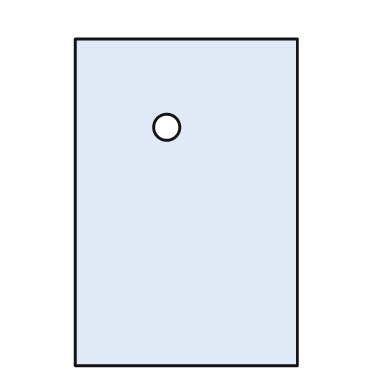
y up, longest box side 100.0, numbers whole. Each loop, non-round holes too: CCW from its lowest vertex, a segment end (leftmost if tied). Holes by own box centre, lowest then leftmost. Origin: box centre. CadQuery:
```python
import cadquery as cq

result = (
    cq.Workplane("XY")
    .moveTo(-34.0, -50.0)
    .lineTo(34.0, -50.0)
    .lineTo(34.0, 50.0)
    .lineTo(-34.0, 50.0)
    .close()
    .moveTo(-6.0, 23.0)
    .circle(4.0)
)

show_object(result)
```